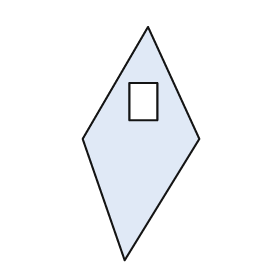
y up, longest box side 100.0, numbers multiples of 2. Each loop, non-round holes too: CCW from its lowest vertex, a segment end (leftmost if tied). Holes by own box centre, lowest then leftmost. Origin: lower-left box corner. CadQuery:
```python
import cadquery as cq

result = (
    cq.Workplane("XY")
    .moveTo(18.0, 0.0)
    .lineTo(50.0, 52.0)
    .lineTo(28.0, 100.0)
    .lineTo(0.0, 52.0)
    .close()
    .moveTo(20.0, 60.0)
    .lineTo(32.0, 60.0)
    .lineTo(32.0, 76.0)
    .lineTo(20.0, 76.0)
    .close()
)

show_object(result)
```